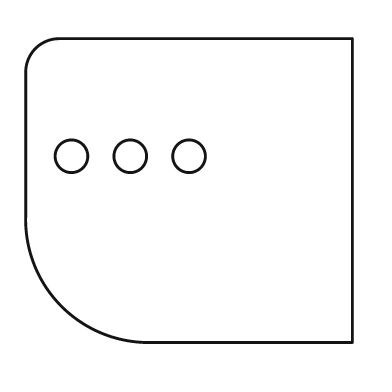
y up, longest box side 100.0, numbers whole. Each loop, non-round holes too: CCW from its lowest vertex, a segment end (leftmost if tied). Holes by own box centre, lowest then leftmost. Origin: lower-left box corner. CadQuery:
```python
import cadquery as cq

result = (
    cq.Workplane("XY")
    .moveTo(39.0, 0.0)
    .lineTo(100.0, 0.0)
    .lineTo(100.0, 93.0)
    .lineTo(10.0, 93.0)
    .threePointArc((3.0, 90.0), (0.0, 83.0))
    .lineTo(0.0, 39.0)
    .threePointArc((11.0, 11.0), (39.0, 0.0))
    .close()
    .moveTo(14.0, 57.0)
    .circle(5.0)
    .moveTo(32.0, 57.0)
    .circle(5.0)
    .moveTo(50.0, 57.0)
    .circle(5.0)
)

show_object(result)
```